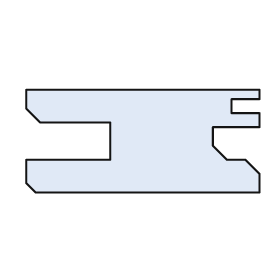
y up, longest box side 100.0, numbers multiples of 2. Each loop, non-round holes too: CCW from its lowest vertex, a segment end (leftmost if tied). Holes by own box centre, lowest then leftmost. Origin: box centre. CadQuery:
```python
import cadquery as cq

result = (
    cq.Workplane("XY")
    .moveTo(-46.0, -22.0)
    .lineTo(50.0, -22.0)
    .lineTo(50.0, -14.0)
    .lineTo(44.0, -8.0)
    .lineTo(36.0, -8.0)
    .lineTo(30.0, -2.0)
    .lineTo(30.0, 6.0)
    .lineTo(50.0, 6.0)
    .lineTo(50.0, 12.0)
    .lineTo(38.0, 12.0)
    .lineTo(38.0, 18.0)
    .lineTo(50.0, 18.0)
    .lineTo(50.0, 22.0)
    .lineTo(-50.0, 22.0)
    .lineTo(-50.0, 14.0)
    .lineTo(-44.0, 8.0)
    .lineTo(-14.0, 8.0)
    .lineTo(-14.0, -8.0)
    .lineTo(-50.0, -8.0)
    .lineTo(-50.0, -18.0)
    .close()
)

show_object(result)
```